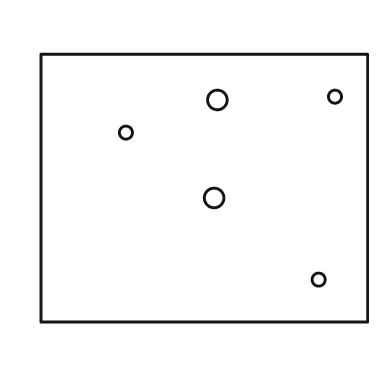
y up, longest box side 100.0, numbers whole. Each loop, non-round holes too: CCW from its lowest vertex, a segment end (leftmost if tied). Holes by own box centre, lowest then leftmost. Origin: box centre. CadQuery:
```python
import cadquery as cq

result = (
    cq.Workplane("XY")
    .moveTo(-50.0, -41.0)
    .lineTo(50.0, -41.0)
    .lineTo(50.0, 41.0)
    .lineTo(-50.0, 41.0)
    .close()
    .moveTo(35.0, -28.0)
    .circle(2.0)
    .moveTo(3.0, -3.0)
    .circle(3.0)
    .moveTo(-24.0, 17.0)
    .circle(2.0)
    .moveTo(4.0, 27.0)
    .circle(3.0)
    .moveTo(40.0, 28.0)
    .circle(2.0)
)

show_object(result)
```